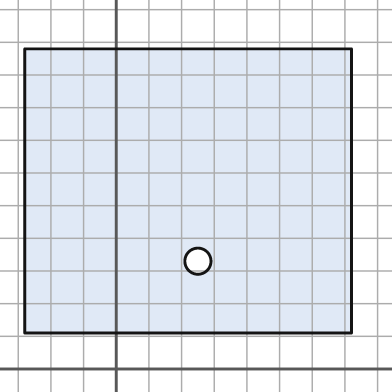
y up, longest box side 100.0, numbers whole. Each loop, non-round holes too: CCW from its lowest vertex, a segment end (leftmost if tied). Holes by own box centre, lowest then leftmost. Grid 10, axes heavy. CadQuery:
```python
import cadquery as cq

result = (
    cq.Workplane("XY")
    .moveTo(-28.0, 11.0)
    .lineTo(72.0, 11.0)
    .lineTo(72.0, 98.0)
    .lineTo(-28.0, 98.0)
    .close()
    .moveTo(25.0, 33.0)
    .circle(4.0)
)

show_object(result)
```